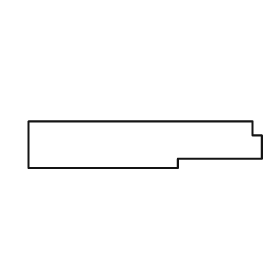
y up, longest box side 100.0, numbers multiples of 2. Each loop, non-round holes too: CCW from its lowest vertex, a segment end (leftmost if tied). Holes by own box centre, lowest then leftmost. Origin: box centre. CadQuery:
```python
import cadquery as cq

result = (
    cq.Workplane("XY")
    .moveTo(-50.0, -10.0)
    .lineTo(14.0, -10.0)
    .lineTo(14.0, -6.0)
    .lineTo(50.0, -6.0)
    .lineTo(50.0, 4.0)
    .lineTo(46.0, 4.0)
    .lineTo(46.0, 10.0)
    .lineTo(-50.0, 10.0)
    .close()
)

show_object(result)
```